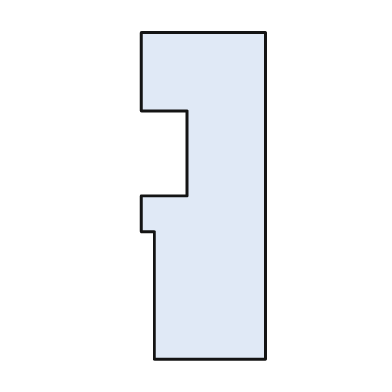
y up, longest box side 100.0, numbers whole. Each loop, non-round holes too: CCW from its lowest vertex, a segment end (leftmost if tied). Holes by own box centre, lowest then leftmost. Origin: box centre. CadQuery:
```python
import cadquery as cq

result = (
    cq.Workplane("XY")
    .moveTo(-15.0, -50.0)
    .lineTo(19.0, -50.0)
    .lineTo(19.0, 50.0)
    .lineTo(-19.0, 50.0)
    .lineTo(-19.0, 26.0)
    .lineTo(-5.0, 26.0)
    .lineTo(-5.0, 0.0)
    .lineTo(-19.0, 0.0)
    .lineTo(-19.0, -11.0)
    .lineTo(-15.0, -11.0)
    .close()
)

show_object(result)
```